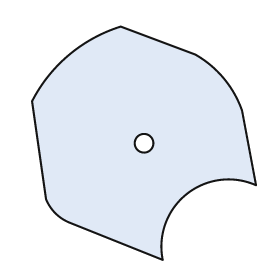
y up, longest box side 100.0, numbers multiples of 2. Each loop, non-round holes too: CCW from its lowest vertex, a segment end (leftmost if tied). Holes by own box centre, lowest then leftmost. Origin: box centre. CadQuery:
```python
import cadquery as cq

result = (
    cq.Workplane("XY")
    .moveTo(8.0, -50.0)
    .threePointArc((18.0, -22.0), (48.0, -18.0))
    .lineTo(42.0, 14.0)
    .threePointArc((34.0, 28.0), (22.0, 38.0))
    .lineTo(-10.0, 50.0)
    .threePointArc((-32.0, 38.0), (-48.0, 18.0))
    .lineTo(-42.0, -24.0)
    .threePointArc((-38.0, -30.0), (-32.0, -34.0))
    .close()
    .moveTo(0.0, 0.0)
    .circle(4.0)
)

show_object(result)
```